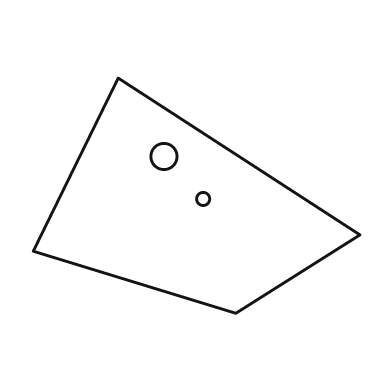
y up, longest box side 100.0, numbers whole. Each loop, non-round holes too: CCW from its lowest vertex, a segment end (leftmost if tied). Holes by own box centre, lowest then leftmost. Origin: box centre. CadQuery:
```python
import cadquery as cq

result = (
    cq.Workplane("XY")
    .moveTo(12.0, -36.0)
    .lineTo(50.0, -12.0)
    .lineTo(-24.0, 36.0)
    .lineTo(-50.0, -17.0)
    .close()
    .moveTo(2.0, -1.0)
    .circle(2.0)
    .moveTo(-10.0, 12.0)
    .circle(4.0)
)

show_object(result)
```